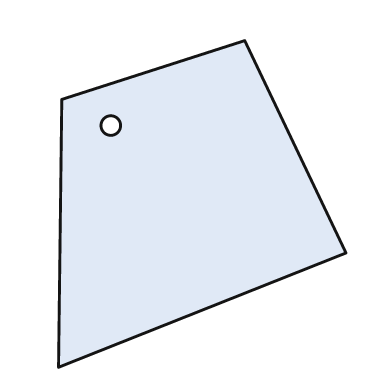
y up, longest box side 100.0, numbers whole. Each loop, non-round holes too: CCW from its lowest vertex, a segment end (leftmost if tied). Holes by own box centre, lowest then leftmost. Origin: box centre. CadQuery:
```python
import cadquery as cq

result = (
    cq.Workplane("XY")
    .moveTo(-44.0, -50.0)
    .lineTo(44.0, -15.0)
    .lineTo(13.0, 50.0)
    .lineTo(-43.0, 32.0)
    .close()
    .moveTo(-28.0, 24.0)
    .circle(3.0)
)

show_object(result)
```